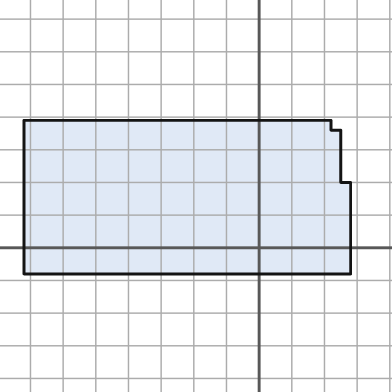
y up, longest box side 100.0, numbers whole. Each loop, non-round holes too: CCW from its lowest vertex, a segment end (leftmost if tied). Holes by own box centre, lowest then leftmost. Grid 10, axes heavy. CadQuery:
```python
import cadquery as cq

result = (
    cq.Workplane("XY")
    .moveTo(-72.0, -8.0)
    .lineTo(28.0, -8.0)
    .lineTo(28.0, 20.0)
    .lineTo(25.0, 20.0)
    .lineTo(25.0, 36.0)
    .lineTo(22.0, 36.0)
    .lineTo(22.0, 39.0)
    .lineTo(-72.0, 39.0)
    .close()
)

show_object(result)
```